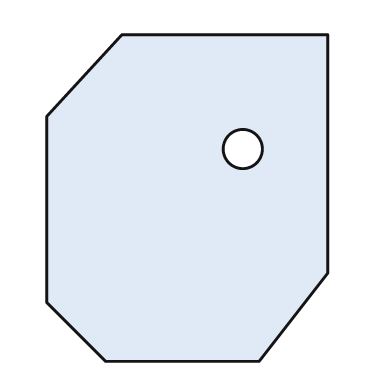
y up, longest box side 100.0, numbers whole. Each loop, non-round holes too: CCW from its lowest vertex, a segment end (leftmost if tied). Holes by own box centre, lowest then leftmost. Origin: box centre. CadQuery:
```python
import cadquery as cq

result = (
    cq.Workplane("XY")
    .moveTo(-25.0, -50.0)
    .lineTo(22.0, -50.0)
    .lineTo(43.0, -23.0)
    .lineTo(43.0, 50.0)
    .lineTo(-20.0, 50.0)
    .lineTo(-43.0, 25.0)
    .lineTo(-43.0, -32.0)
    .close()
    .moveTo(17.0, 15.0)
    .circle(6.0)
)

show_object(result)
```